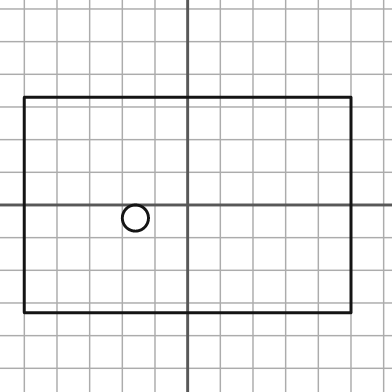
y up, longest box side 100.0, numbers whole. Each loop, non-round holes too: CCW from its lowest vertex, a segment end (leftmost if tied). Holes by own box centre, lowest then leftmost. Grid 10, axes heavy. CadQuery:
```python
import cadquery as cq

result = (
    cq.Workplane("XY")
    .moveTo(-50.0, -33.0)
    .lineTo(50.0, -33.0)
    .lineTo(50.0, 33.0)
    .lineTo(-50.0, 33.0)
    .close()
    .moveTo(-16.0, -4.0)
    .circle(4.0)
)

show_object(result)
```